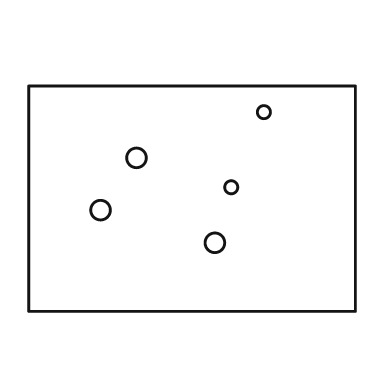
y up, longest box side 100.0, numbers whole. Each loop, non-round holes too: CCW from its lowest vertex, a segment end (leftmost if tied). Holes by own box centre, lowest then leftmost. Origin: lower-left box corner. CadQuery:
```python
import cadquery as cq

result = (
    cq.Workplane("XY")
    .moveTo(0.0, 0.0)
    .lineTo(100.0, 0.0)
    .lineTo(100.0, 69.0)
    .lineTo(0.0, 69.0)
    .close()
    .moveTo(57.0, 21.0)
    .circle(3.0)
    .moveTo(22.0, 31.0)
    .circle(3.0)
    .moveTo(62.0, 38.0)
    .circle(2.0)
    .moveTo(33.0, 47.0)
    .circle(3.0)
    .moveTo(72.0, 61.0)
    .circle(2.0)
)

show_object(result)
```